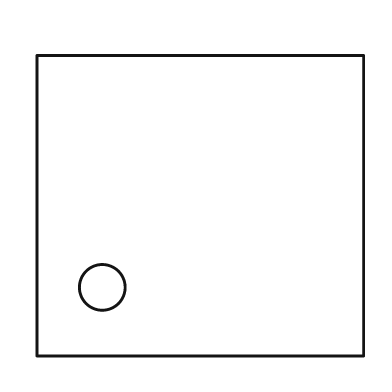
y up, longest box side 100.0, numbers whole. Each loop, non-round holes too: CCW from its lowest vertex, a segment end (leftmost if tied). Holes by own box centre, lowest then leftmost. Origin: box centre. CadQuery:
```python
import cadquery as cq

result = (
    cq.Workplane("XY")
    .moveTo(-50.0, -46.0)
    .lineTo(50.0, -46.0)
    .lineTo(50.0, 46.0)
    .lineTo(-50.0, 46.0)
    .close()
    .moveTo(-30.0, -25.0)
    .circle(7.0)
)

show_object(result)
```